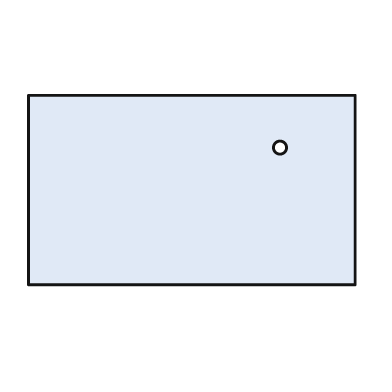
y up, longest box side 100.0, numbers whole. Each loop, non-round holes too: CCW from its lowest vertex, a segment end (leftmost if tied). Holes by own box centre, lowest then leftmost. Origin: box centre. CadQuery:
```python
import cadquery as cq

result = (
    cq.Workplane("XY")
    .moveTo(-50.0, -29.0)
    .lineTo(50.0, -29.0)
    .lineTo(50.0, 29.0)
    .lineTo(-50.0, 29.0)
    .close()
    .moveTo(27.0, 13.0)
    .circle(2.0)
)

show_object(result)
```